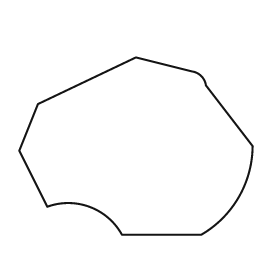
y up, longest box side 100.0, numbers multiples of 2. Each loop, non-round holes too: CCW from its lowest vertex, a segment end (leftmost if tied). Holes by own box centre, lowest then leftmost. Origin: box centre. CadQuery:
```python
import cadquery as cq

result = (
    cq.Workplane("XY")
    .moveTo(-6.0, -38.0)
    .lineTo(28.0, -38.0)
    .threePointArc((44.0, -22.0), (50.0, 0.0))
    .lineTo(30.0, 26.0)
    .threePointArc((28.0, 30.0), (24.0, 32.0))
    .lineTo(0.0, 38.0)
    .lineTo(-42.0, 18.0)
    .lineTo(-50.0, -2.0)
    .lineTo(-38.0, -26.0)
    .threePointArc((-20.0, -26.0), (-6.0, -38.0))
    .close()
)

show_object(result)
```